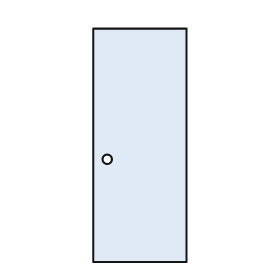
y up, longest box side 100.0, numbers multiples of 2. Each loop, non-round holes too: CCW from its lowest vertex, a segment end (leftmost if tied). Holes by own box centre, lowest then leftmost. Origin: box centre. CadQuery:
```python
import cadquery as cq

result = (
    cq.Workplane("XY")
    .moveTo(-20.0, -50.0)
    .lineTo(20.0, -50.0)
    .lineTo(20.0, 50.0)
    .lineTo(-20.0, 50.0)
    .close()
    .moveTo(-14.0, -6.0)
    .circle(2.0)
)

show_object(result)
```